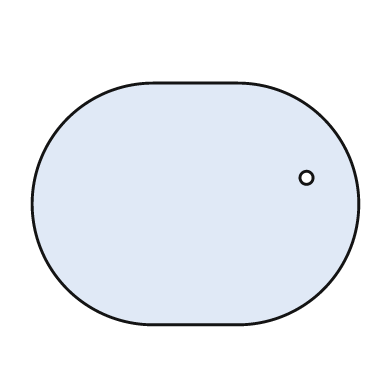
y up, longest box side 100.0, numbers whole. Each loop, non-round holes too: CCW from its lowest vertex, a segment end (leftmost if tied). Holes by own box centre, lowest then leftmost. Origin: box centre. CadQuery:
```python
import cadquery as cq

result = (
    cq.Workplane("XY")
    .moveTo(-13.0, -37.0)
    .lineTo(13.0, -37.0)
    .threePointArc((50.0, 0.0), (13.0, 37.0))
    .lineTo(-13.0, 37.0)
    .threePointArc((-50.0, 0.0), (-13.0, -37.0))
    .close()
    .moveTo(34.0, 8.0)
    .circle(2.0)
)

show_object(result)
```